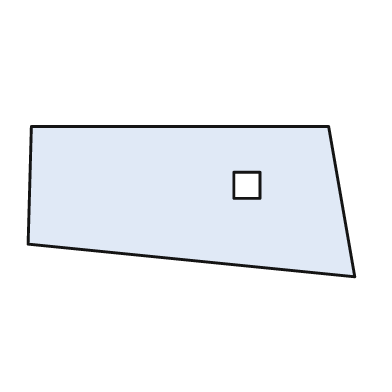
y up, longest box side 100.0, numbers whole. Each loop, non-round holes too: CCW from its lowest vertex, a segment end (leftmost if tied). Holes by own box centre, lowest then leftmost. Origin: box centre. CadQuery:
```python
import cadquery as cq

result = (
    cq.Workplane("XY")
    .moveTo(50.0, -23.0)
    .lineTo(42.0, 23.0)
    .lineTo(-49.0, 23.0)
    .lineTo(-50.0, -13.0)
    .close()
    .moveTo(13.0, 1.0)
    .lineTo(21.0, 1.0)
    .lineTo(21.0, 9.0)
    .lineTo(13.0, 9.0)
    .close()
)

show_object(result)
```